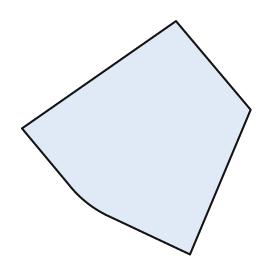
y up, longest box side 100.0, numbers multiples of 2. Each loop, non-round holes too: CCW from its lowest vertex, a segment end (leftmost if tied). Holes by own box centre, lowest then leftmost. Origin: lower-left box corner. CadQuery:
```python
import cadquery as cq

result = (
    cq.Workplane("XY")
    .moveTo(72.0, 0.0)
    .lineTo(98.0, 62.0)
    .lineTo(66.0, 100.0)
    .lineTo(0.0, 54.0)
    .lineTo(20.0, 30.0)
    .threePointArc((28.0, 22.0), (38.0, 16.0))
    .close()
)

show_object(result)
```